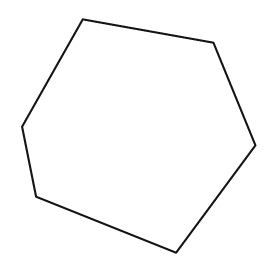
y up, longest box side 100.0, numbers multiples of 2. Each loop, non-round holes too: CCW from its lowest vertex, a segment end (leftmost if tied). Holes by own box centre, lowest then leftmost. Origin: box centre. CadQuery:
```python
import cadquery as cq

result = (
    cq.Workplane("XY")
    .moveTo(16.0, -50.0)
    .lineTo(50.0, -4.0)
    .lineTo(32.0, 40.0)
    .lineTo(-24.0, 50.0)
    .lineTo(-50.0, 4.0)
    .lineTo(-44.0, -26.0)
    .close()
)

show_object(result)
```